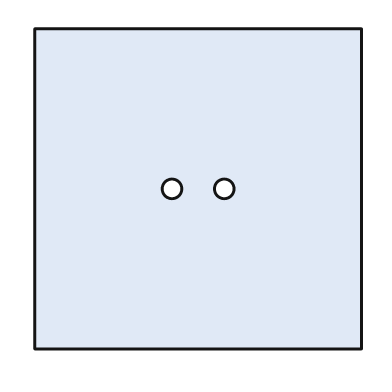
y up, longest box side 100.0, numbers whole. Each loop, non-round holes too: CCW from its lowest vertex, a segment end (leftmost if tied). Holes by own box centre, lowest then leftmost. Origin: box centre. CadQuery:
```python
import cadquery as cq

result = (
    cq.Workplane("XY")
    .moveTo(-50.0, -49.0)
    .lineTo(50.0, -49.0)
    .lineTo(50.0, 49.0)
    .lineTo(-50.0, 49.0)
    .close()
    .moveTo(-8.0, 0.0)
    .circle(3.0)
    .moveTo(8.0, 0.0)
    .circle(3.0)
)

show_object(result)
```